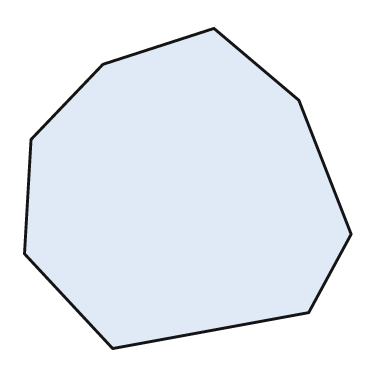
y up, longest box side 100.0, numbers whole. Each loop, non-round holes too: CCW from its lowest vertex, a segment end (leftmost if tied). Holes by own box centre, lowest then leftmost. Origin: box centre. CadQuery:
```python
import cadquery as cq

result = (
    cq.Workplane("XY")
    .moveTo(-23.0, -49.0)
    .lineTo(37.0, -38.0)
    .lineTo(50.0, -14.0)
    .lineTo(34.0, 27.0)
    .lineTo(8.0, 49.0)
    .lineTo(-26.0, 38.0)
    .lineTo(-48.0, 15.0)
    .lineTo(-50.0, -20.0)
    .close()
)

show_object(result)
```